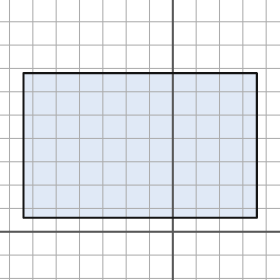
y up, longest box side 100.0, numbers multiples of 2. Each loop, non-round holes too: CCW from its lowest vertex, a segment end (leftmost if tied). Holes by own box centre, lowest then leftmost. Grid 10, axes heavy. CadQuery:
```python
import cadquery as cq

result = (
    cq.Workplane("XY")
    .moveTo(-64.0, 6.0)
    .lineTo(36.0, 6.0)
    .lineTo(36.0, 68.0)
    .lineTo(-64.0, 68.0)
    .close()
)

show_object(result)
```